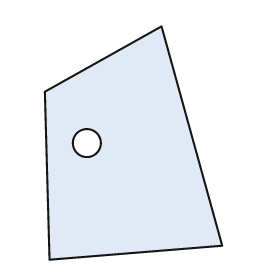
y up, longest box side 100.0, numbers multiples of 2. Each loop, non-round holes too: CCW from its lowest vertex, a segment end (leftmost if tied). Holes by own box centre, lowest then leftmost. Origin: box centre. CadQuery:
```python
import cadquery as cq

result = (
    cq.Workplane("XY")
    .moveTo(-36.0, -50.0)
    .lineTo(38.0, -44.0)
    .lineTo(12.0, 50.0)
    .lineTo(-38.0, 22.0)
    .close()
    .moveTo(-20.0, 0.0)
    .circle(6.0)
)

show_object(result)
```